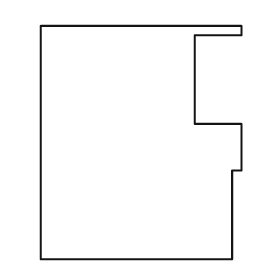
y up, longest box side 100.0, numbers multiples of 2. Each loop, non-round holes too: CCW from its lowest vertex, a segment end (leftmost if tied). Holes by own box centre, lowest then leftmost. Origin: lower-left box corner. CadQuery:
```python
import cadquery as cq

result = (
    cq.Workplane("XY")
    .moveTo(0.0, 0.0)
    .lineTo(82.0, 0.0)
    .lineTo(82.0, 38.0)
    .lineTo(86.0, 38.0)
    .lineTo(86.0, 58.0)
    .lineTo(66.0, 58.0)
    .lineTo(66.0, 96.0)
    .lineTo(86.0, 96.0)
    .lineTo(86.0, 100.0)
    .lineTo(0.0, 100.0)
    .close()
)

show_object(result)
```